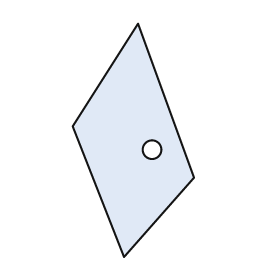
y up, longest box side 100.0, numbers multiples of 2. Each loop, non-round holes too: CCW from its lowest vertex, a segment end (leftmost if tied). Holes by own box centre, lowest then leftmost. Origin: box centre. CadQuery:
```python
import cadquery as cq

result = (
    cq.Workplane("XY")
    .moveTo(-4.0, -50.0)
    .lineTo(26.0, -16.0)
    .lineTo(2.0, 50.0)
    .lineTo(-26.0, 6.0)
    .close()
    .moveTo(8.0, -4.0)
    .circle(4.0)
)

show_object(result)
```